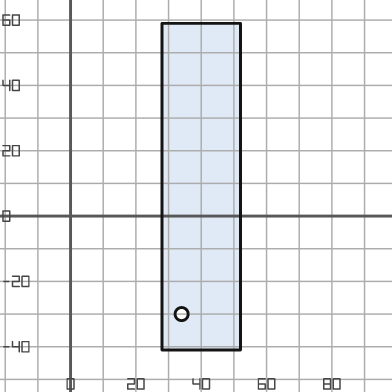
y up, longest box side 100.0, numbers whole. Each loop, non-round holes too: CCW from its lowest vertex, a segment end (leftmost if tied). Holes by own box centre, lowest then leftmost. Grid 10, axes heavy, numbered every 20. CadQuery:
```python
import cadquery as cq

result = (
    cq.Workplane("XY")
    .moveTo(28.0, -41.0)
    .lineTo(52.0, -41.0)
    .lineTo(52.0, 59.0)
    .lineTo(28.0, 59.0)
    .close()
    .moveTo(34.0, -30.0)
    .circle(2.0)
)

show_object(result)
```